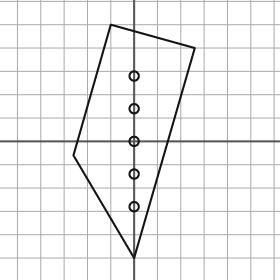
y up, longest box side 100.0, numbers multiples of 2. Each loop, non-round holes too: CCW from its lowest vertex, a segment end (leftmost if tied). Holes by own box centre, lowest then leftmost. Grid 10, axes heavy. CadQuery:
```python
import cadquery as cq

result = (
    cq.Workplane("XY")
    .moveTo(0.0, -50.0)
    .lineTo(26.0, 40.0)
    .lineTo(-10.0, 50.0)
    .lineTo(-26.0, -6.0)
    .close()
    .moveTo(0.0, -28.0)
    .circle(2.0)
    .moveTo(0.0, -14.0)
    .circle(2.0)
    .moveTo(0.0, 0.0)
    .circle(2.0)
    .moveTo(0.0, 14.0)
    .circle(2.0)
    .moveTo(0.0, 28.0)
    .circle(2.0)
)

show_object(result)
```